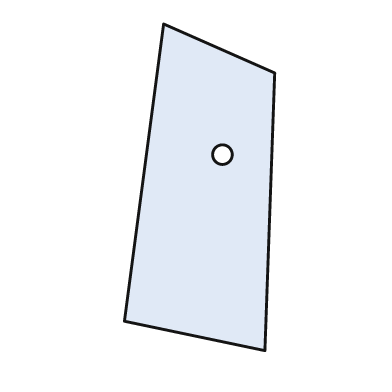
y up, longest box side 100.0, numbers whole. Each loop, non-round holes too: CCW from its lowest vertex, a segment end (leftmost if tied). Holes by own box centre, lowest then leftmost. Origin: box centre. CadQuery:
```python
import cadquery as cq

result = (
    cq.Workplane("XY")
    .moveTo(20.0, -50.0)
    .lineTo(23.0, 35.0)
    .lineTo(-11.0, 50.0)
    .lineTo(-23.0, -41.0)
    .close()
    .moveTo(7.0, 10.0)
    .circle(3.0)
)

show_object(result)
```